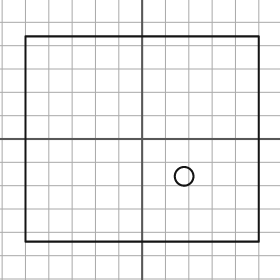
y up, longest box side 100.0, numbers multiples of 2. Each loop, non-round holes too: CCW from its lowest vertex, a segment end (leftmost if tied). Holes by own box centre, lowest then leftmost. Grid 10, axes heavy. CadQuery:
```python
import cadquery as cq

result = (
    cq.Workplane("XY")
    .moveTo(-50.0, -44.0)
    .lineTo(50.0, -44.0)
    .lineTo(50.0, 44.0)
    .lineTo(-50.0, 44.0)
    .close()
    .moveTo(18.0, -16.0)
    .circle(4.0)
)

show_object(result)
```